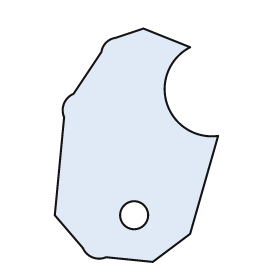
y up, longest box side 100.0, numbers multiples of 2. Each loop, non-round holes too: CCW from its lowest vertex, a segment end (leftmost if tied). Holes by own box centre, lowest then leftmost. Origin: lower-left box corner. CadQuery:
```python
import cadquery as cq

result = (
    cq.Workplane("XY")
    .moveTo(42.0, 0.0)
    .lineTo(58.0, 12.0)
    .lineTo(70.0, 54.0)
    .threePointArc((48.0, 68.0), (58.0, 92.0))
    .lineTo(38.0, 100.0)
    .lineTo(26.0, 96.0)
    .threePointArc((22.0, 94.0), (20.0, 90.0))
    .lineTo(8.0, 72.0)
    .threePointArc((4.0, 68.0), (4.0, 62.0))
    .lineTo(0.0, 20.0)
    .lineTo(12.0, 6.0)
    .threePointArc((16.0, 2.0), (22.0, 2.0))
    .close()
    .moveTo(34.0, 20.0)
    .circle(6.0)
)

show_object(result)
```